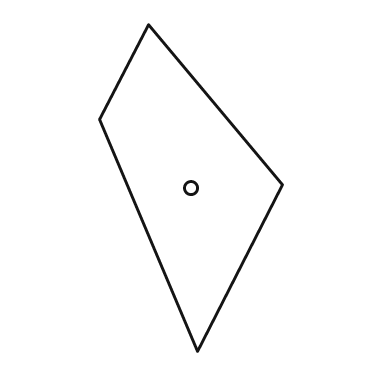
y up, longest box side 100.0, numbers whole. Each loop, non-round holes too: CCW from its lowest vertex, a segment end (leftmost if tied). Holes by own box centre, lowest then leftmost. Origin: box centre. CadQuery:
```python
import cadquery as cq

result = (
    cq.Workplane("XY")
    .moveTo(2.0, -50.0)
    .lineTo(28.0, 1.0)
    .lineTo(-13.0, 50.0)
    .lineTo(-28.0, 21.0)
    .close()
    .moveTo(0.0, 0.0)
    .circle(2.0)
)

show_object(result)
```